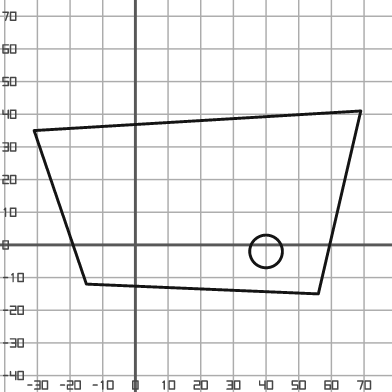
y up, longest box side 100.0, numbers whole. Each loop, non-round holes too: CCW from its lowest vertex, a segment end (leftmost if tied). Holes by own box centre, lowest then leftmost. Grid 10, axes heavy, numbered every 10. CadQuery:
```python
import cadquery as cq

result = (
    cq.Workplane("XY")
    .moveTo(56.0, -15.0)
    .lineTo(69.0, 41.0)
    .lineTo(-31.0, 35.0)
    .lineTo(-15.0, -12.0)
    .close()
    .moveTo(40.0, -2.0)
    .circle(5.0)
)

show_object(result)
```